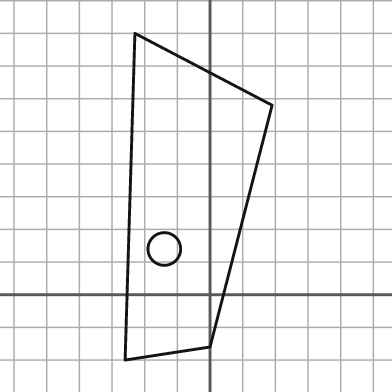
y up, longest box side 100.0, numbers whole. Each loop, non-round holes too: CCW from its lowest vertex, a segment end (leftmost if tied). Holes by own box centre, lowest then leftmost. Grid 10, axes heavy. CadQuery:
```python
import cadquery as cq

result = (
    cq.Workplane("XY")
    .moveTo(-26.0, -20.0)
    .lineTo(0.0, -16.0)
    .lineTo(19.0, 58.0)
    .lineTo(-23.0, 80.0)
    .close()
    .moveTo(-14.0, 14.0)
    .circle(5.0)
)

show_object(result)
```